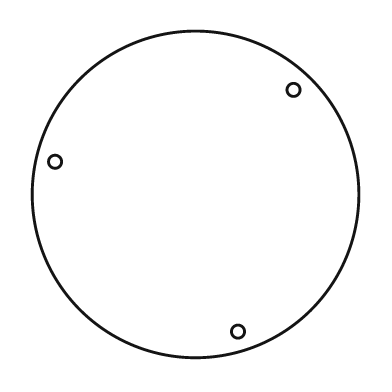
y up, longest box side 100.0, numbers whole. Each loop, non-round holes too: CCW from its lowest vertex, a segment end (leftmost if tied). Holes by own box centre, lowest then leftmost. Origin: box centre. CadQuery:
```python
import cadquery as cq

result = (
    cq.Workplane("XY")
    .moveTo(0.0, 0.0)
    .circle(50.0)
    .moveTo(13.0, -42.0)
    .circle(2.0)
    .moveTo(-43.0, 10.0)
    .circle(2.0)
    .moveTo(30.0, 32.0)
    .circle(2.0)
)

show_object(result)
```